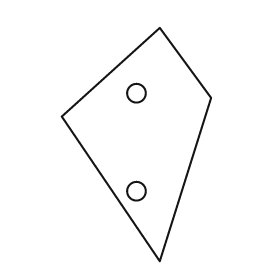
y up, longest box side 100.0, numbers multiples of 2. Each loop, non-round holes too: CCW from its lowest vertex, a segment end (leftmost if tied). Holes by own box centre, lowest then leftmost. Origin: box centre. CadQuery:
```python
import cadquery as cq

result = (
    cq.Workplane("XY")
    .moveTo(10.0, -50.0)
    .lineTo(32.0, 20.0)
    .lineTo(10.0, 50.0)
    .lineTo(-32.0, 12.0)
    .close()
    .moveTo(0.0, -20.0)
    .circle(4.0)
    .moveTo(0.0, 22.0)
    .circle(4.0)
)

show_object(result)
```